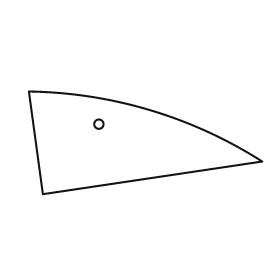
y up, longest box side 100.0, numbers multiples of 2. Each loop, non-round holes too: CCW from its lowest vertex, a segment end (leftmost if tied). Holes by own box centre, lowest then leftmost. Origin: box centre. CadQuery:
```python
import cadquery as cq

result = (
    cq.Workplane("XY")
    .moveTo(-44.0, -22.0)
    .lineTo(50.0, -8.0)
    .threePointArc((2.0, 14.0), (-50.0, 22.0))
    .close()
    .moveTo(-20.0, 8.0)
    .circle(2.0)
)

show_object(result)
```